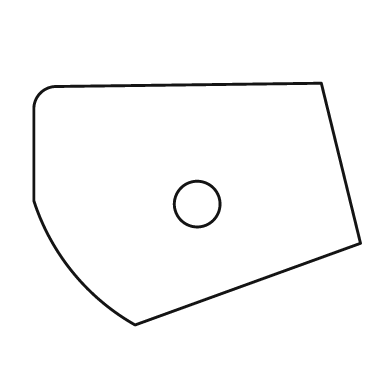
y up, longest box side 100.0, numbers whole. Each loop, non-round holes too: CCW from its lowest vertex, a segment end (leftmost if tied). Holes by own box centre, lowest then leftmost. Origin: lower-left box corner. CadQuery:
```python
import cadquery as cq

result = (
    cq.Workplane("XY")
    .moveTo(31.0, 0.0)
    .lineTo(100.0, 25.0)
    .lineTo(88.0, 74.0)
    .lineTo(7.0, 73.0)
    .threePointArc((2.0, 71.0), (0.0, 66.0))
    .lineTo(0.0, 38.0)
    .threePointArc((12.0, 16.0), (31.0, 0.0))
    .close()
    .moveTo(50.0, 37.0)
    .circle(7.0)
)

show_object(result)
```